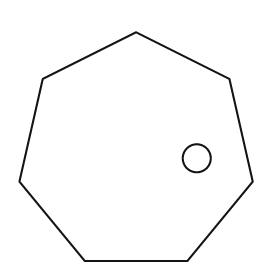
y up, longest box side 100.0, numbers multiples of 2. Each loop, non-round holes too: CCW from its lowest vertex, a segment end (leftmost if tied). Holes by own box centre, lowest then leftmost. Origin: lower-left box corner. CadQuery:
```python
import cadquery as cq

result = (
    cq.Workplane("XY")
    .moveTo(28.0, 0.0)
    .lineTo(72.0, 0.0)
    .lineTo(100.0, 34.0)
    .lineTo(90.0, 78.0)
    .lineTo(50.0, 98.0)
    .lineTo(10.0, 78.0)
    .lineTo(0.0, 34.0)
    .close()
    .moveTo(76.0, 44.0)
    .circle(6.0)
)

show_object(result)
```